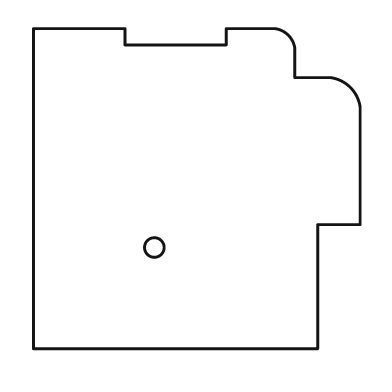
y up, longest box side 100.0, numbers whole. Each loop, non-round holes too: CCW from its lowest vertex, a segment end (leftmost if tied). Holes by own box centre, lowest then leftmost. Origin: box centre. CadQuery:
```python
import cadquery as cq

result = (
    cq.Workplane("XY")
    .moveTo(-50.0, -49.0)
    .lineTo(37.0, -49.0)
    .lineTo(37.0, -11.0)
    .lineTo(50.0, -11.0)
    .lineTo(50.0, 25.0)
    .threePointArc((47.0, 31.0), (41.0, 34.0))
    .lineTo(30.0, 34.0)
    .lineTo(30.0, 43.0)
    .threePointArc((28.0, 47.0), (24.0, 49.0))
    .lineTo(9.0, 49.0)
    .lineTo(9.0, 44.0)
    .lineTo(-22.0, 44.0)
    .lineTo(-22.0, 49.0)
    .lineTo(-50.0, 49.0)
    .close()
    .moveTo(-13.0, -18.0)
    .circle(3.0)
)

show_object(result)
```